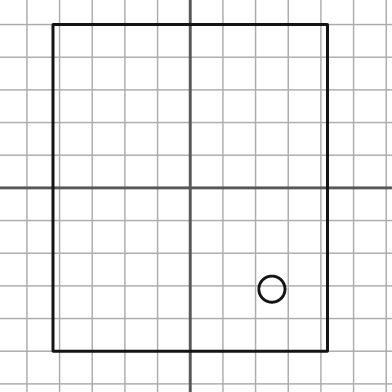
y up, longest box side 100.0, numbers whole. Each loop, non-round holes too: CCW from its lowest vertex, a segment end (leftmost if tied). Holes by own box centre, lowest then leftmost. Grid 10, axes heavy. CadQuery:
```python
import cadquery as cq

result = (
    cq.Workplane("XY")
    .moveTo(-42.0, -50.0)
    .lineTo(42.0, -50.0)
    .lineTo(42.0, 50.0)
    .lineTo(-42.0, 50.0)
    .close()
    .moveTo(25.0, -31.0)
    .circle(4.0)
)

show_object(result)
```